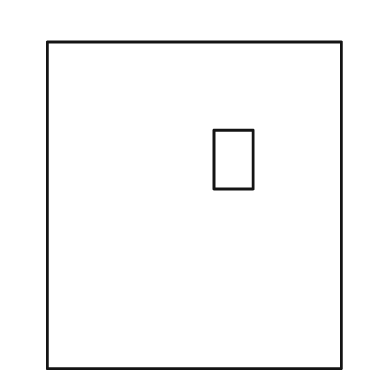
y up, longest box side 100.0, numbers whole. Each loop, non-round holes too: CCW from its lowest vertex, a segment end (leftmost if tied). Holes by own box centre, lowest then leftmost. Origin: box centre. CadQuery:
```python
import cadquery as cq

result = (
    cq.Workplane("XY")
    .moveTo(-45.0, -50.0)
    .lineTo(45.0, -50.0)
    .lineTo(45.0, 50.0)
    .lineTo(-45.0, 50.0)
    .close()
    .moveTo(6.0, 5.0)
    .lineTo(18.0, 5.0)
    .lineTo(18.0, 23.0)
    .lineTo(6.0, 23.0)
    .close()
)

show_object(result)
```